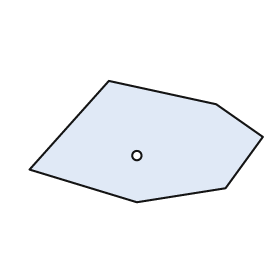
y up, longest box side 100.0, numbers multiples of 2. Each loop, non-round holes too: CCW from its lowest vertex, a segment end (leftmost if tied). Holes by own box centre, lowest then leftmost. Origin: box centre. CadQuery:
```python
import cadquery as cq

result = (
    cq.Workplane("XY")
    .moveTo(-4.0, -26.0)
    .lineTo(34.0, -20.0)
    .lineTo(50.0, 2.0)
    .lineTo(30.0, 16.0)
    .lineTo(-16.0, 26.0)
    .lineTo(-50.0, -12.0)
    .close()
    .moveTo(-4.0, -6.0)
    .circle(2.0)
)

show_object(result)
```